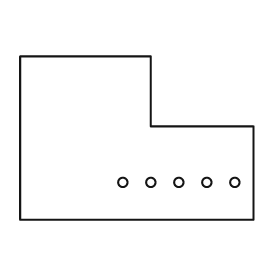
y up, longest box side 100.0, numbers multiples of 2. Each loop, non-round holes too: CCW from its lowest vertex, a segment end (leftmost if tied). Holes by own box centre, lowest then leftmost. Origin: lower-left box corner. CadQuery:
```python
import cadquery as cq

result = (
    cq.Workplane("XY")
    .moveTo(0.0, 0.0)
    .lineTo(100.0, 0.0)
    .lineTo(100.0, 40.0)
    .lineTo(56.0, 40.0)
    .lineTo(56.0, 70.0)
    .lineTo(0.0, 70.0)
    .close()
    .moveTo(44.0, 16.0)
    .circle(2.0)
    .moveTo(56.0, 16.0)
    .circle(2.0)
    .moveTo(68.0, 16.0)
    .circle(2.0)
    .moveTo(80.0, 16.0)
    .circle(2.0)
    .moveTo(92.0, 16.0)
    .circle(2.0)
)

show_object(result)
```